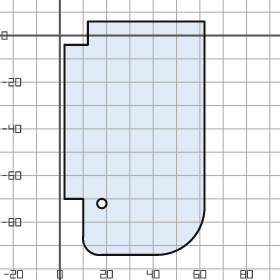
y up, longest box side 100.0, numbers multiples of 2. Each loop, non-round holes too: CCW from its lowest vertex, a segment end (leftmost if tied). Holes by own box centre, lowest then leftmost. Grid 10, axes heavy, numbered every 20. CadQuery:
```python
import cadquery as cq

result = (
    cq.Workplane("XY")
    .moveTo(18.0, -94.0)
    .lineTo(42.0, -94.0)
    .threePointArc((56.0, -88.0), (62.0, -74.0))
    .lineTo(62.0, 6.0)
    .lineTo(12.0, 6.0)
    .lineTo(12.0, -4.0)
    .lineTo(2.0, -4.0)
    .lineTo(2.0, -70.0)
    .lineTo(10.0, -70.0)
    .lineTo(10.0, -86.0)
    .threePointArc((12.0, -92.0), (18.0, -94.0))
    .close()
    .moveTo(18.0, -72.0)
    .circle(2.0)
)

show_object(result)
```